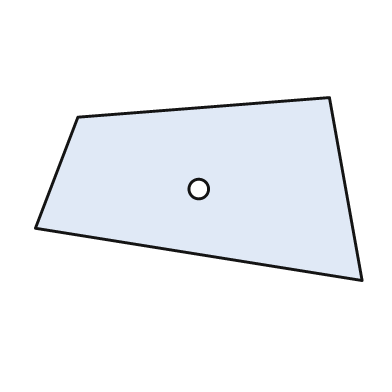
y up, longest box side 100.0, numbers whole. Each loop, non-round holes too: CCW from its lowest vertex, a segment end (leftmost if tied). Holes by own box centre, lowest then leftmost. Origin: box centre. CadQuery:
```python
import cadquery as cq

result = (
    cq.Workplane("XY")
    .moveTo(50.0, -28.0)
    .lineTo(40.0, 28.0)
    .lineTo(-37.0, 22.0)
    .lineTo(-50.0, -12.0)
    .close()
    .moveTo(0.0, 0.0)
    .circle(3.0)
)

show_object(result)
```